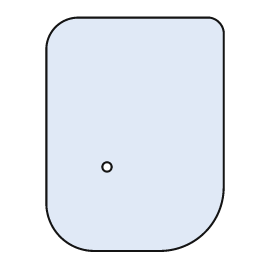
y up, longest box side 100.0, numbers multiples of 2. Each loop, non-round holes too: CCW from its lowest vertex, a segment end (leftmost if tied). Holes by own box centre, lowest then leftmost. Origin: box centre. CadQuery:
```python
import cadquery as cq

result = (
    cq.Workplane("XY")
    .moveTo(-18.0, -50.0)
    .lineTo(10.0, -50.0)
    .threePointArc((30.0, -42.0), (38.0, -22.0))
    .lineTo(38.0, 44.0)
    .threePointArc((36.0, 48.0), (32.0, 50.0))
    .lineTo(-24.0, 50.0)
    .threePointArc((-34.0, 46.0), (-38.0, 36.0))
    .lineTo(-38.0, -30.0)
    .threePointArc((-32.0, -44.0), (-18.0, -50.0))
    .close()
    .moveTo(-12.0, -14.0)
    .circle(2.0)
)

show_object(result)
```